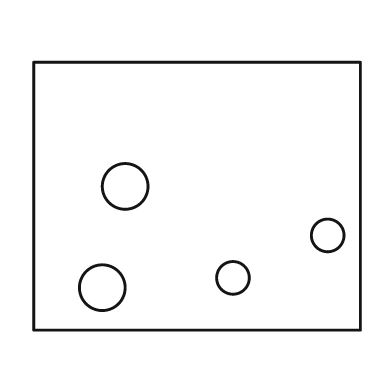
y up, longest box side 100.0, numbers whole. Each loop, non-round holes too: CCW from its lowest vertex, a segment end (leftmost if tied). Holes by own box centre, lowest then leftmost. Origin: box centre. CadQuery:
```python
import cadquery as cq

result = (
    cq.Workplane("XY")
    .moveTo(-50.0, -41.0)
    .lineTo(50.0, -41.0)
    .lineTo(50.0, 41.0)
    .lineTo(-50.0, 41.0)
    .close()
    .moveTo(-29.0, -28.0)
    .circle(7.0)
    .moveTo(11.0, -25.0)
    .circle(5.0)
    .moveTo(40.0, -12.0)
    .circle(5.0)
    .moveTo(-22.0, 3.0)
    .circle(7.0)
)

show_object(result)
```